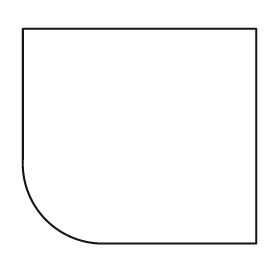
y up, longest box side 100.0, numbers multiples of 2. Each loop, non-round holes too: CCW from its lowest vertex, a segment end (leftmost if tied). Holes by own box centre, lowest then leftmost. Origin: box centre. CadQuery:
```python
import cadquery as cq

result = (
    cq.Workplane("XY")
    .moveTo(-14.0, -46.0)
    .lineTo(50.0, -46.0)
    .lineTo(50.0, 46.0)
    .lineTo(-50.0, 46.0)
    .lineTo(-50.0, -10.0)
    .threePointArc((-40.0, -36.0), (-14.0, -46.0))
    .close()
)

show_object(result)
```